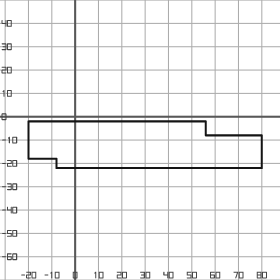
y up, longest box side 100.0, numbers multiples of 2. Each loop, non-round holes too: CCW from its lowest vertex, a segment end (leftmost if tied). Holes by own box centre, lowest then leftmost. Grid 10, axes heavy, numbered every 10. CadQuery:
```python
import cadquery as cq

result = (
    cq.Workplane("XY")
    .moveTo(-8.0, -22.0)
    .lineTo(80.0, -22.0)
    .lineTo(80.0, -8.0)
    .lineTo(56.0, -8.0)
    .lineTo(56.0, -2.0)
    .lineTo(-20.0, -2.0)
    .lineTo(-20.0, -18.0)
    .lineTo(-8.0, -18.0)
    .close()
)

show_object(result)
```